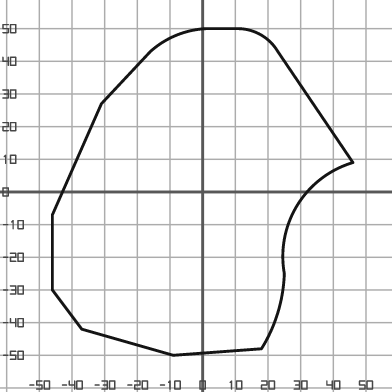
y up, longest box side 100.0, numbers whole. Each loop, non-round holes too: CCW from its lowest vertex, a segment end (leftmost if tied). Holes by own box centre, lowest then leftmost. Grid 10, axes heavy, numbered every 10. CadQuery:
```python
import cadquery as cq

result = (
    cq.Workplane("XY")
    .moveTo(-9.0, -50.0)
    .lineTo(18.0, -48.0)
    .threePointArc((23.0, -37.0), (25.0, -25.0))
    .threePointArc((29.0, -4.0), (46.0, 9.0))
    .lineTo(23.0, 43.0)
    .threePointArc((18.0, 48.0), (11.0, 50.0))
    .lineTo(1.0, 50.0)
    .threePointArc((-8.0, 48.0), (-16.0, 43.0))
    .lineTo(-31.0, 27.0)
    .lineTo(-46.0, -7.0)
    .lineTo(-46.0, -30.0)
    .lineTo(-37.0, -42.0)
    .close()
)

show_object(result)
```